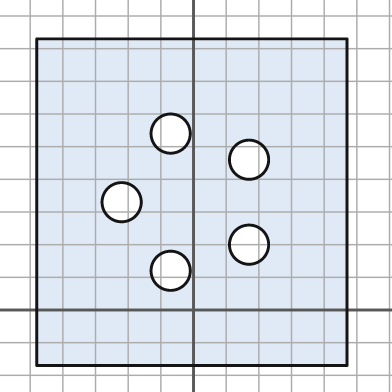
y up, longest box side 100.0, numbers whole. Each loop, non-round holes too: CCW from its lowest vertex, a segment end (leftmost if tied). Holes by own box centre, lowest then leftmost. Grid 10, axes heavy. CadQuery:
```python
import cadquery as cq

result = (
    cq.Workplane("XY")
    .moveTo(-48.0, -17.0)
    .lineTo(47.0, -17.0)
    .lineTo(47.0, 83.0)
    .lineTo(-48.0, 83.0)
    .close()
    .moveTo(-7.0, 12.0)
    .circle(6.0)
    .moveTo(17.0, 20.0)
    .circle(6.0)
    .moveTo(-22.0, 33.0)
    .circle(6.0)
    .moveTo(17.0, 46.0)
    .circle(6.0)
    .moveTo(-7.0, 54.0)
    .circle(6.0)
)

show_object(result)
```